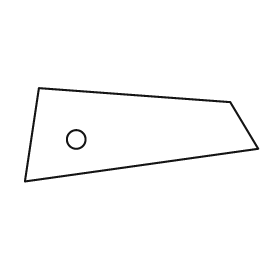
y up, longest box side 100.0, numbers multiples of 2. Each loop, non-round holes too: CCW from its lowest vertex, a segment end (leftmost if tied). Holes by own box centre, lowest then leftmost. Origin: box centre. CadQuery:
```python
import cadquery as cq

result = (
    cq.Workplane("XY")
    .moveTo(-50.0, -20.0)
    .lineTo(50.0, -6.0)
    .lineTo(38.0, 14.0)
    .lineTo(-44.0, 20.0)
    .close()
    .moveTo(-28.0, -2.0)
    .circle(4.0)
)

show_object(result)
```